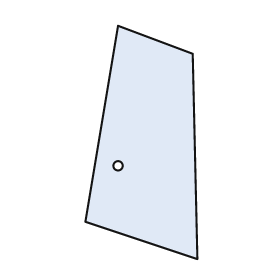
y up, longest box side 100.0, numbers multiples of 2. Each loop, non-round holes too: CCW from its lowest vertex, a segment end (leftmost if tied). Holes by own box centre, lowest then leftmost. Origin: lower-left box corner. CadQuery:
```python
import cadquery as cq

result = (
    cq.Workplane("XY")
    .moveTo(48.0, 0.0)
    .lineTo(46.0, 88.0)
    .lineTo(14.0, 100.0)
    .lineTo(0.0, 16.0)
    .close()
    .moveTo(14.0, 40.0)
    .circle(2.0)
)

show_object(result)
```